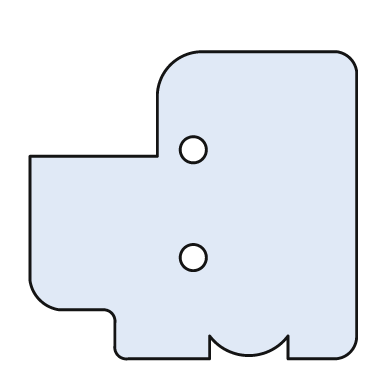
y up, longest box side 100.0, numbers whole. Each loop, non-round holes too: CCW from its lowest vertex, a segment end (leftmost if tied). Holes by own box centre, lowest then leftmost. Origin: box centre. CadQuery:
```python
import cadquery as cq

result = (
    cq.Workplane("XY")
    .moveTo(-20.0, -47.0)
    .lineTo(5.0, -47.0)
    .lineTo(5.0, -40.0)
    .threePointArc((17.0, -46.0), (29.0, -40.0))
    .lineTo(29.0, -47.0)
    .lineTo(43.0, -47.0)
    .threePointArc((48.0, -45.0), (50.0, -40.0))
    .lineTo(50.0, 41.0)
    .threePointArc((48.0, 45.0), (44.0, 47.0))
    .lineTo(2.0, 47.0)
    .threePointArc((-7.0, 43.0), (-11.0, 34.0))
    .lineTo(-11.0, 15.0)
    .lineTo(-50.0, 15.0)
    .lineTo(-50.0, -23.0)
    .threePointArc((-47.0, -29.0), (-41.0, -32.0))
    .lineTo(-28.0, -32.0)
    .threePointArc((-25.0, -33.0), (-24.0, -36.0))
    .lineTo(-24.0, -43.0)
    .threePointArc((-23.0, -46.0), (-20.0, -47.0))
    .close()
    .moveTo(0.0, -16.0)
    .circle(4.0)
    .moveTo(0.0, 17.0)
    .circle(4.0)
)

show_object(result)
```